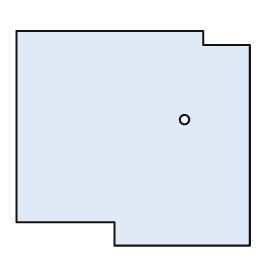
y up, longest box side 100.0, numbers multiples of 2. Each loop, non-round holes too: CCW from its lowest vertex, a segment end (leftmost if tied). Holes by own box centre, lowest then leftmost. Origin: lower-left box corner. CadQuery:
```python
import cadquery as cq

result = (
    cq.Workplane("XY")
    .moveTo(42.0, 0.0)
    .lineTo(100.0, 0.0)
    .lineTo(100.0, 86.0)
    .lineTo(80.0, 86.0)
    .lineTo(80.0, 92.0)
    .lineTo(0.0, 92.0)
    .lineTo(0.0, 10.0)
    .lineTo(42.0, 10.0)
    .close()
    .moveTo(72.0, 54.0)
    .circle(2.0)
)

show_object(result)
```